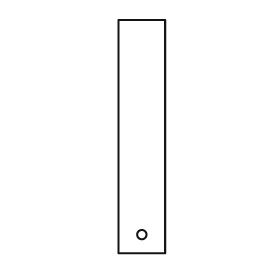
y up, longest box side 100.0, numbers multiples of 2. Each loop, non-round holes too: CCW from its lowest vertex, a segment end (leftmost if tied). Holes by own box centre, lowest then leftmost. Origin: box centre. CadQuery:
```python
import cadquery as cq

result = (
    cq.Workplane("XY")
    .moveTo(-10.0, -50.0)
    .lineTo(10.0, -50.0)
    .lineTo(10.0, 50.0)
    .lineTo(-10.0, 50.0)
    .close()
    .moveTo(0.0, -42.0)
    .circle(2.0)
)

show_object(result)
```